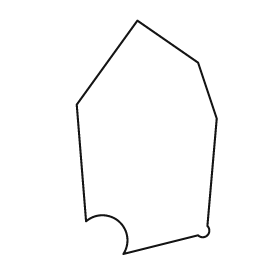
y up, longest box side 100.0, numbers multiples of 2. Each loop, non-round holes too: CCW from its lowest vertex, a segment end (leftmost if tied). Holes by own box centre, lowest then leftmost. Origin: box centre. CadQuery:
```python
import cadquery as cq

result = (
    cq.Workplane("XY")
    .moveTo(-10.0, -50.0)
    .lineTo(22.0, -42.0)
    .threePointArc((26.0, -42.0), (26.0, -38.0))
    .lineTo(30.0, 8.0)
    .lineTo(22.0, 32.0)
    .lineTo(-4.0, 50.0)
    .lineTo(-30.0, 14.0)
    .lineTo(-26.0, -36.0)
    .threePointArc((-12.0, -36.0), (-10.0, -50.0))
    .close()
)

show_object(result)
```